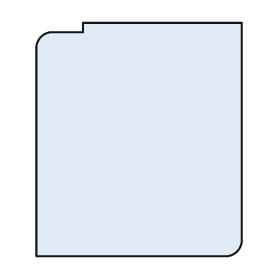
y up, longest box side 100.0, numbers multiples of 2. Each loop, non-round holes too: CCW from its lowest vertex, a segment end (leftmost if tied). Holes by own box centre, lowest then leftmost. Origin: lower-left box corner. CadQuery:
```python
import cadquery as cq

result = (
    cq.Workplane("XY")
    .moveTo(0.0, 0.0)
    .lineTo(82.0, 0.0)
    .threePointArc((86.0, 2.0), (88.0, 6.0))
    .lineTo(88.0, 100.0)
    .lineTo(20.0, 100.0)
    .lineTo(20.0, 96.0)
    .lineTo(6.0, 96.0)
    .threePointArc((2.0, 94.0), (0.0, 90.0))
    .close()
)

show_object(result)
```